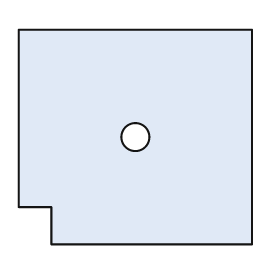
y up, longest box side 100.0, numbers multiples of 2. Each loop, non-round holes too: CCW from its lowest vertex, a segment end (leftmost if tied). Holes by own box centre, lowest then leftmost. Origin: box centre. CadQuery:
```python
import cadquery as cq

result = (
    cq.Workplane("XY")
    .moveTo(-36.0, -46.0)
    .lineTo(50.0, -46.0)
    .lineTo(50.0, 46.0)
    .lineTo(-50.0, 46.0)
    .lineTo(-50.0, -30.0)
    .lineTo(-36.0, -30.0)
    .close()
    .moveTo(0.0, 0.0)
    .circle(6.0)
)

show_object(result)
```